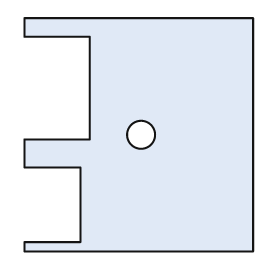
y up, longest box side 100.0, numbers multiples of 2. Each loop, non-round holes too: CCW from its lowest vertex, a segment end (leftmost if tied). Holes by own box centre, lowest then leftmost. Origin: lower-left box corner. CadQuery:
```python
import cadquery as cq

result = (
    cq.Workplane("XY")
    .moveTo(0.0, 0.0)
    .lineTo(98.0, 0.0)
    .lineTo(98.0, 100.0)
    .lineTo(0.0, 100.0)
    .lineTo(0.0, 92.0)
    .lineTo(28.0, 92.0)
    .lineTo(28.0, 48.0)
    .lineTo(0.0, 48.0)
    .lineTo(0.0, 36.0)
    .lineTo(24.0, 36.0)
    .lineTo(24.0, 4.0)
    .lineTo(0.0, 4.0)
    .close()
    .moveTo(50.0, 50.0)
    .circle(6.0)
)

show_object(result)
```